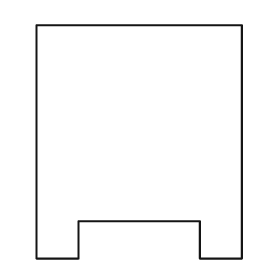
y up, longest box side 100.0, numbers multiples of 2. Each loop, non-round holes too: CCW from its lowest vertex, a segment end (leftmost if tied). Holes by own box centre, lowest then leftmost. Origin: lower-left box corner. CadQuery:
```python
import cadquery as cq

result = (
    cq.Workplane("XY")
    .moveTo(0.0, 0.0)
    .lineTo(18.0, 0.0)
    .lineTo(18.0, 16.0)
    .lineTo(70.0, 16.0)
    .lineTo(70.0, 0.0)
    .lineTo(88.0, 0.0)
    .lineTo(88.0, 100.0)
    .lineTo(0.0, 100.0)
    .close()
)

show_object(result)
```